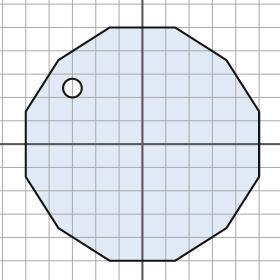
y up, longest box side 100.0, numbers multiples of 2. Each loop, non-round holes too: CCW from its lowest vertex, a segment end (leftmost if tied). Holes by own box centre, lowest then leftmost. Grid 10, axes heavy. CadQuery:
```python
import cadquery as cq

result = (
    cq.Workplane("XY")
    .moveTo(-14.0, -50.0)
    .lineTo(14.0, -50.0)
    .lineTo(36.0, -36.0)
    .lineTo(50.0, -14.0)
    .lineTo(50.0, 14.0)
    .lineTo(36.0, 36.0)
    .lineTo(14.0, 50.0)
    .lineTo(-14.0, 50.0)
    .lineTo(-36.0, 36.0)
    .lineTo(-50.0, 14.0)
    .lineTo(-50.0, -14.0)
    .lineTo(-36.0, -36.0)
    .close()
    .moveTo(-30.0, 24.0)
    .circle(4.0)
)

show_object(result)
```